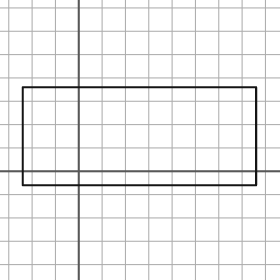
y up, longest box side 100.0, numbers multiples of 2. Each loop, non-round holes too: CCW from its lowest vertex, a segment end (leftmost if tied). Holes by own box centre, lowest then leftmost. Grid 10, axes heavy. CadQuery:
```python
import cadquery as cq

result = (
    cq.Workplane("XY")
    .moveTo(-24.0, -6.0)
    .lineTo(76.0, -6.0)
    .lineTo(76.0, 36.0)
    .lineTo(-24.0, 36.0)
    .close()
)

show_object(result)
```